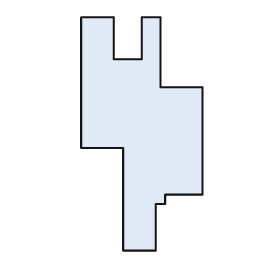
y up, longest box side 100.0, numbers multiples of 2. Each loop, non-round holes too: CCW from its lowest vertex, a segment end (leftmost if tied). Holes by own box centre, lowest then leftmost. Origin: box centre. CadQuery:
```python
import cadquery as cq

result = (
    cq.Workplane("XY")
    .moveTo(-8.0, -50.0)
    .lineTo(6.0, -50.0)
    .lineTo(6.0, -30.0)
    .lineTo(10.0, -30.0)
    .lineTo(10.0, -26.0)
    .lineTo(26.0, -26.0)
    .lineTo(26.0, 20.0)
    .lineTo(8.0, 20.0)
    .lineTo(8.0, 50.0)
    .lineTo(0.0, 50.0)
    .lineTo(0.0, 32.0)
    .lineTo(-12.0, 32.0)
    .lineTo(-12.0, 50.0)
    .lineTo(-26.0, 50.0)
    .lineTo(-26.0, -6.0)
    .lineTo(-8.0, -6.0)
    .close()
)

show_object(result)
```